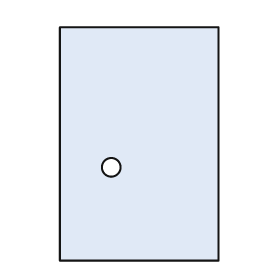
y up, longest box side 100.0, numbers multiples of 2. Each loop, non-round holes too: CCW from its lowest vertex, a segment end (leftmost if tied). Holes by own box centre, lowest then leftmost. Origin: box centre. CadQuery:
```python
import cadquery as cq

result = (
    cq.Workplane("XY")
    .moveTo(-34.0, -50.0)
    .lineTo(34.0, -50.0)
    .lineTo(34.0, 50.0)
    .lineTo(-34.0, 50.0)
    .close()
    .moveTo(-12.0, -10.0)
    .circle(4.0)
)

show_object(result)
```